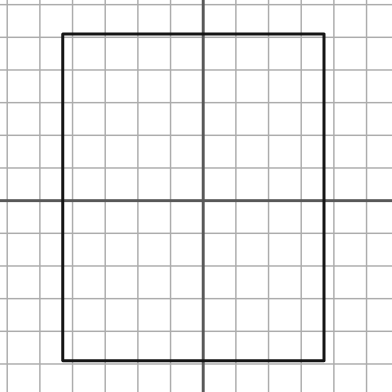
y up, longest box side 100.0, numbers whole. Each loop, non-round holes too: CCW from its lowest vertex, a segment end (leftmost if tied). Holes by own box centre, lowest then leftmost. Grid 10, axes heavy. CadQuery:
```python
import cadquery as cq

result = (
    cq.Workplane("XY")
    .moveTo(-43.0, -49.0)
    .lineTo(37.0, -49.0)
    .lineTo(37.0, 51.0)
    .lineTo(-43.0, 51.0)
    .close()
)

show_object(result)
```